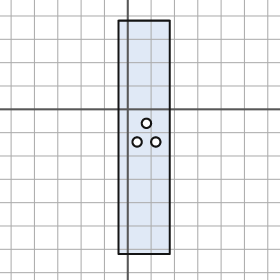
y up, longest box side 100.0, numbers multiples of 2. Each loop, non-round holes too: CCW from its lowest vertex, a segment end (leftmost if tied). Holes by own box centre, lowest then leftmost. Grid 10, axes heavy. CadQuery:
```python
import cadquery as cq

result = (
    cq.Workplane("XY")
    .moveTo(-4.0, -62.0)
    .lineTo(18.0, -62.0)
    .lineTo(18.0, 38.0)
    .lineTo(-4.0, 38.0)
    .close()
    .moveTo(4.0, -14.0)
    .circle(2.0)
    .moveTo(12.0, -14.0)
    .circle(2.0)
    .moveTo(8.0, -6.0)
    .circle(2.0)
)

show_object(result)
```